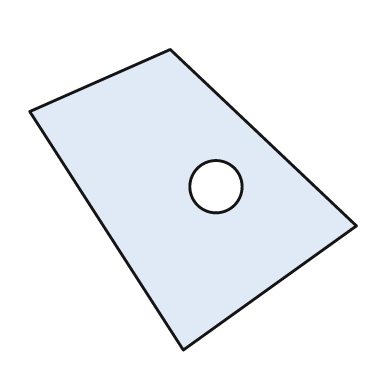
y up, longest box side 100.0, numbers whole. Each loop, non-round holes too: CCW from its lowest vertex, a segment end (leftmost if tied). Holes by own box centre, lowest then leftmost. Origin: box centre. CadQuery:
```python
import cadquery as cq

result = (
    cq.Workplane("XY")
    .moveTo(-3.0, -46.0)
    .lineTo(50.0, -8.0)
    .lineTo(-7.0, 46.0)
    .lineTo(-50.0, 27.0)
    .close()
    .moveTo(7.0, 4.0)
    .circle(8.0)
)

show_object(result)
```